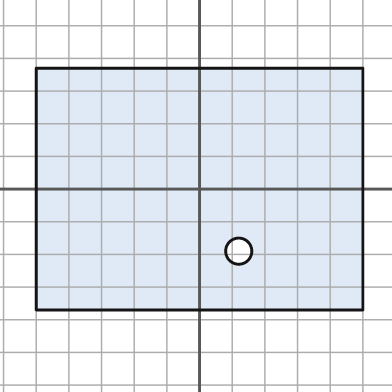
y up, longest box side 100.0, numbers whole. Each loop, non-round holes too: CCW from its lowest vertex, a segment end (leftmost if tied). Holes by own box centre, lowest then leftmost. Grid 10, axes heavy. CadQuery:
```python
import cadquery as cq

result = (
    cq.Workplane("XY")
    .moveTo(-50.0, -37.0)
    .lineTo(50.0, -37.0)
    .lineTo(50.0, 37.0)
    .lineTo(-50.0, 37.0)
    .close()
    .moveTo(12.0, -19.0)
    .circle(4.0)
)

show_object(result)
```